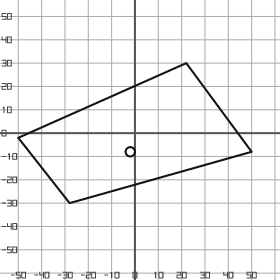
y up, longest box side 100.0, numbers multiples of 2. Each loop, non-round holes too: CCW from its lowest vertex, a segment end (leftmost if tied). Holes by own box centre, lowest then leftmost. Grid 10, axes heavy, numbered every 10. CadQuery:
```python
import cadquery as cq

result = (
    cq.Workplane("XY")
    .moveTo(-28.0, -30.0)
    .lineTo(50.0, -8.0)
    .lineTo(22.0, 30.0)
    .lineTo(-50.0, -2.0)
    .close()
    .moveTo(-2.0, -8.0)
    .circle(2.0)
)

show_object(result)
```